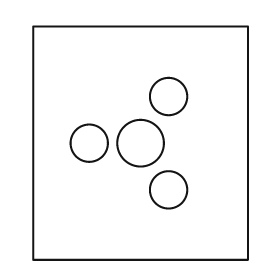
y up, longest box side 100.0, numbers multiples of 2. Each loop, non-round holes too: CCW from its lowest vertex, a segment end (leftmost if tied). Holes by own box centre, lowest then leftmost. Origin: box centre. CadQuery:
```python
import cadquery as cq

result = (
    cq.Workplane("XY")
    .moveTo(-46.0, -50.0)
    .lineTo(46.0, -50.0)
    .lineTo(46.0, 50.0)
    .lineTo(-46.0, 50.0)
    .close()
    .moveTo(12.0, -20.0)
    .circle(8.0)
    .moveTo(-22.0, 0.0)
    .circle(8.0)
    .moveTo(0.0, 0.0)
    .circle(10.0)
    .moveTo(12.0, 20.0)
    .circle(8.0)
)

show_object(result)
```